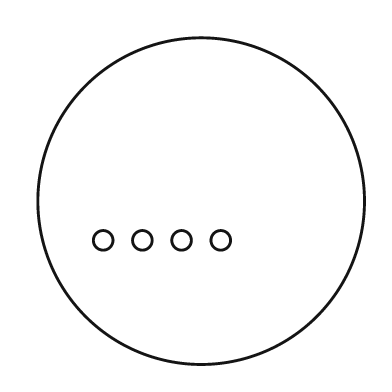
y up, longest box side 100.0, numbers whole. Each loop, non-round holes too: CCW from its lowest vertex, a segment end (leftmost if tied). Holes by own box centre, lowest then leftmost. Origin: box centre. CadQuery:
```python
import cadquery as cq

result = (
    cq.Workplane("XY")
    .moveTo(0.0, 0.0)
    .circle(50.0)
    .moveTo(-30.0, -12.0)
    .circle(3.0)
    .moveTo(-18.0, -12.0)
    .circle(3.0)
    .moveTo(-6.0, -12.0)
    .circle(3.0)
    .moveTo(6.0, -12.0)
    .circle(3.0)
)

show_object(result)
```